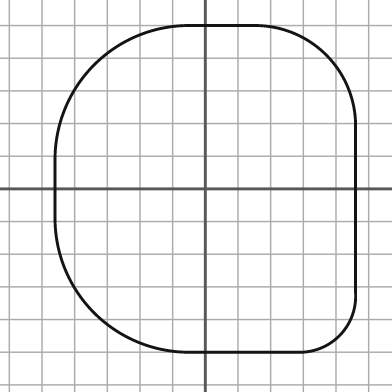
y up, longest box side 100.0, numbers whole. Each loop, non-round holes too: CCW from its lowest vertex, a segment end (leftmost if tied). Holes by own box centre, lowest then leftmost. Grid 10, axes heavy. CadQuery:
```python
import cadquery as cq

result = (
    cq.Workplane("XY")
    .moveTo(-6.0, -50.0)
    .lineTo(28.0, -50.0)
    .threePointArc((41.0, -45.0), (46.0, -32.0))
    .lineTo(46.0, 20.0)
    .threePointArc((37.0, 41.0), (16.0, 50.0))
    .lineTo(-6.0, 50.0)
    .threePointArc((-34.0, 38.0), (-46.0, 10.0))
    .lineTo(-46.0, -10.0)
    .threePointArc((-34.0, -38.0), (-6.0, -50.0))
    .close()
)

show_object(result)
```